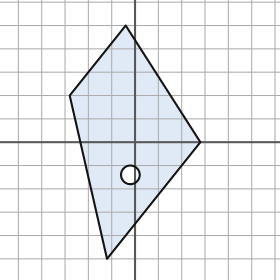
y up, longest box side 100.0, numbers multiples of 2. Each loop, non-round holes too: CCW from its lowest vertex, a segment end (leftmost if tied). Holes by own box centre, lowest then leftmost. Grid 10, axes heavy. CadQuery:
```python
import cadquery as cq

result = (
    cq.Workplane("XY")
    .moveTo(-12.0, -50.0)
    .lineTo(28.0, 0.0)
    .lineTo(-4.0, 50.0)
    .lineTo(-28.0, 20.0)
    .close()
    .moveTo(-2.0, -14.0)
    .circle(4.0)
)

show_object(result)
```